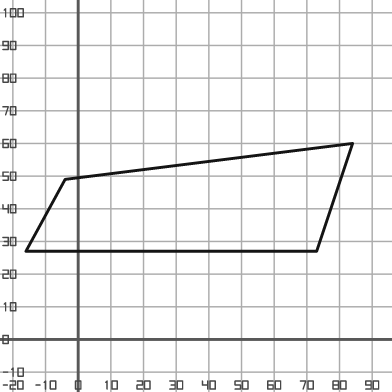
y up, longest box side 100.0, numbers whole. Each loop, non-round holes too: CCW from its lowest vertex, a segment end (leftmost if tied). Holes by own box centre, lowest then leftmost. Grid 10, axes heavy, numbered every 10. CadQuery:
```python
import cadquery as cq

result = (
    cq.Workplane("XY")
    .moveTo(-16.0, 27.0)
    .lineTo(73.0, 27.0)
    .lineTo(84.0, 60.0)
    .lineTo(-4.0, 49.0)
    .close()
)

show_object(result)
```